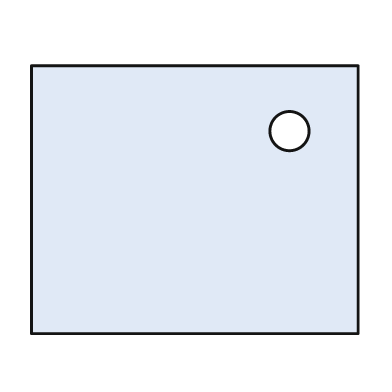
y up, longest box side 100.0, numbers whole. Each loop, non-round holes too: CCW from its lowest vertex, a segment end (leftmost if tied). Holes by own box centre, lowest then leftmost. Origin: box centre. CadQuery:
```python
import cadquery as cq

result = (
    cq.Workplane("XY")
    .moveTo(-50.0, -41.0)
    .lineTo(50.0, -41.0)
    .lineTo(50.0, 41.0)
    .lineTo(-50.0, 41.0)
    .close()
    .moveTo(29.0, 21.0)
    .circle(6.0)
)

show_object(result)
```